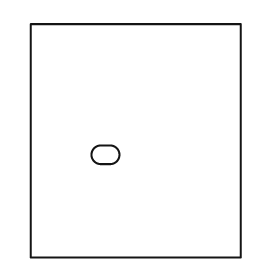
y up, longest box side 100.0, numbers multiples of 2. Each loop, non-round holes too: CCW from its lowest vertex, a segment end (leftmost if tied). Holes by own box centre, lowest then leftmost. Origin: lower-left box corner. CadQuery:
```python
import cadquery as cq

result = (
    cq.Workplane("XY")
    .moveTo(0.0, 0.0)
    .lineTo(90.0, 0.0)
    .lineTo(90.0, 100.0)
    .lineTo(0.0, 100.0)
    .close()
    .moveTo(30.0, 40.0)
    .lineTo(34.0, 40.0)
    .threePointArc((38.0, 44.0), (34.0, 48.0))
    .lineTo(30.0, 48.0)
    .threePointArc((26.0, 44.0), (30.0, 40.0))
    .close()
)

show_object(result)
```